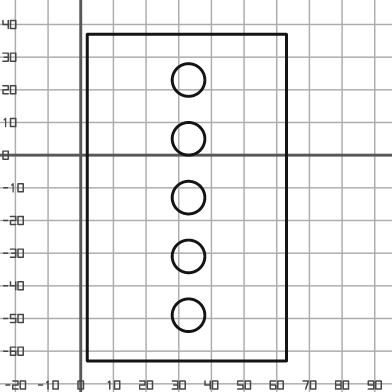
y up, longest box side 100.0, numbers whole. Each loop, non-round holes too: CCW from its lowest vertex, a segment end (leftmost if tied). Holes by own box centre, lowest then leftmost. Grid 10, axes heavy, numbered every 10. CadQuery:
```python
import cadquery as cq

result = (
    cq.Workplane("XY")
    .moveTo(2.0, -63.0)
    .lineTo(63.0, -63.0)
    .lineTo(63.0, 37.0)
    .lineTo(2.0, 37.0)
    .close()
    .moveTo(33.0, -49.0)
    .circle(5.0)
    .moveTo(33.0, -31.0)
    .circle(5.0)
    .moveTo(33.0, -13.0)
    .circle(5.0)
    .moveTo(33.0, 5.0)
    .circle(5.0)
    .moveTo(33.0, 23.0)
    .circle(5.0)
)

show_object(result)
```